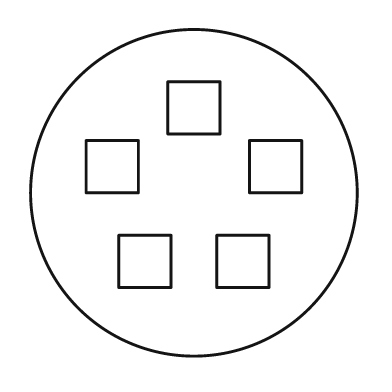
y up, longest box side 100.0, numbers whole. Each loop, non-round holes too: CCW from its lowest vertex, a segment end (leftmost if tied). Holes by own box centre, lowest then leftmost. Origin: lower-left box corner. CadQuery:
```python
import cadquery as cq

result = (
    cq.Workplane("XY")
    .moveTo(50.0, 50.0)
    .circle(50.0)
    .moveTo(27.0, 21.0)
    .lineTo(43.0, 21.0)
    .lineTo(43.0, 37.0)
    .lineTo(27.0, 37.0)
    .close()
    .moveTo(57.0, 21.0)
    .lineTo(73.0, 21.0)
    .lineTo(73.0, 37.0)
    .lineTo(57.0, 37.0)
    .close()
    .moveTo(17.0, 50.0)
    .lineTo(33.0, 50.0)
    .lineTo(33.0, 66.0)
    .lineTo(17.0, 66.0)
    .close()
    .moveTo(67.0, 50.0)
    .lineTo(83.0, 50.0)
    .lineTo(83.0, 66.0)
    .lineTo(67.0, 66.0)
    .close()
    .moveTo(42.0, 68.0)
    .lineTo(58.0, 68.0)
    .lineTo(58.0, 84.0)
    .lineTo(42.0, 84.0)
    .close()
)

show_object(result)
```